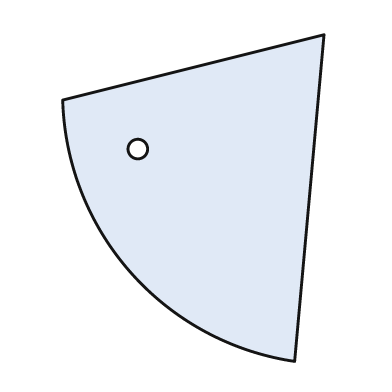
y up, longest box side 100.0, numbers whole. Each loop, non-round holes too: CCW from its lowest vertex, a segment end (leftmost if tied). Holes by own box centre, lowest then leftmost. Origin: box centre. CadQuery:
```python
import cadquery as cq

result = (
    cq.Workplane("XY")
    .moveTo(31.0, -50.0)
    .lineTo(40.0, 50.0)
    .lineTo(-40.0, 30.0)
    .threePointArc((-19.0, -23.0), (31.0, -50.0))
    .close()
    .moveTo(-17.0, 15.0)
    .circle(3.0)
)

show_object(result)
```